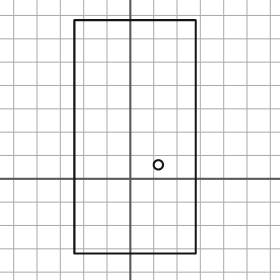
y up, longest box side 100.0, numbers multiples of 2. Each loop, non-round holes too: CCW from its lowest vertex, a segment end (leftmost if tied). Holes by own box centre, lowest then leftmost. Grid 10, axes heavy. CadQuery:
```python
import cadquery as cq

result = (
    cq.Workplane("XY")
    .moveTo(-24.0, -32.0)
    .lineTo(28.0, -32.0)
    .lineTo(28.0, 68.0)
    .lineTo(-24.0, 68.0)
    .close()
    .moveTo(12.0, 6.0)
    .circle(2.0)
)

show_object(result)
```